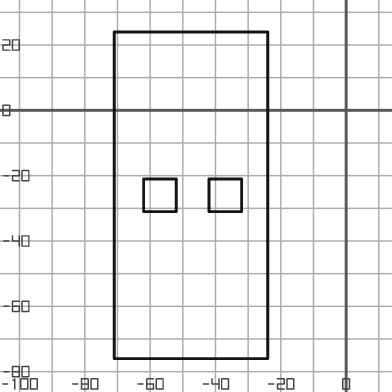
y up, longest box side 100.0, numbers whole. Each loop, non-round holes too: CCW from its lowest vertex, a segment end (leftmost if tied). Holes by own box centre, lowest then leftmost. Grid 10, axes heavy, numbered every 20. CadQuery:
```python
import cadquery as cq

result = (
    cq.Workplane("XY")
    .moveTo(-71.0, -76.0)
    .lineTo(-24.0, -76.0)
    .lineTo(-24.0, 24.0)
    .lineTo(-71.0, 24.0)
    .close()
    .moveTo(-62.0, -31.0)
    .lineTo(-52.0, -31.0)
    .lineTo(-52.0, -21.0)
    .lineTo(-62.0, -21.0)
    .close()
    .moveTo(-42.0, -31.0)
    .lineTo(-32.0, -31.0)
    .lineTo(-32.0, -21.0)
    .lineTo(-42.0, -21.0)
    .close()
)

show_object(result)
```